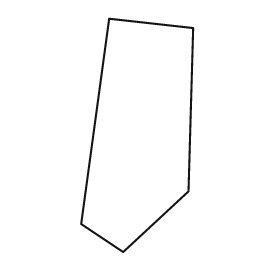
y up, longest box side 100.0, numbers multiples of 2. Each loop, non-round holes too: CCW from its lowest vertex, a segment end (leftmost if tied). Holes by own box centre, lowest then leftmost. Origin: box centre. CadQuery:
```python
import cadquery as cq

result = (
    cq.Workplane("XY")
    .moveTo(-6.0, -50.0)
    .lineTo(22.0, -24.0)
    .lineTo(24.0, 46.0)
    .lineTo(-12.0, 50.0)
    .lineTo(-24.0, -38.0)
    .close()
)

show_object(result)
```